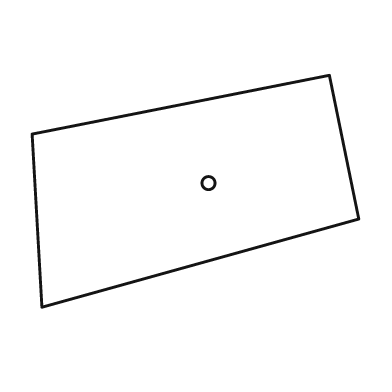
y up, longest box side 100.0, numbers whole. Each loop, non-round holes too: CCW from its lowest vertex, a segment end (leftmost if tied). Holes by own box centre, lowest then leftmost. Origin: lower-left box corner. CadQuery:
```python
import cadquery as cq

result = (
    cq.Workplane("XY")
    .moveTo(3.0, 0.0)
    .lineTo(100.0, 27.0)
    .lineTo(91.0, 71.0)
    .lineTo(0.0, 53.0)
    .close()
    .moveTo(54.0, 38.0)
    .circle(2.0)
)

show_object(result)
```